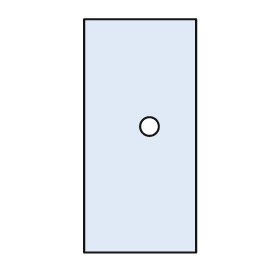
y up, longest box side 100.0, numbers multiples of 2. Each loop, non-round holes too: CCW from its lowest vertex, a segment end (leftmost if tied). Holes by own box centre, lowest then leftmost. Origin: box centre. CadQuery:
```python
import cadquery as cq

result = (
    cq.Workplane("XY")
    .moveTo(-24.0, -50.0)
    .lineTo(24.0, -50.0)
    .lineTo(24.0, 50.0)
    .lineTo(-24.0, 50.0)
    .close()
    .moveTo(4.0, 4.0)
    .circle(4.0)
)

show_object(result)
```